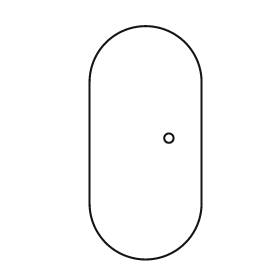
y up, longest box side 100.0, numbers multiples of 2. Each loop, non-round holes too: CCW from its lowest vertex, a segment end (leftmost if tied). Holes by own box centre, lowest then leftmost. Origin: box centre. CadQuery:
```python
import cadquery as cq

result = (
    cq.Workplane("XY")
    .moveTo(-24.0, -26.0)
    .threePointArc((0.0, -50.0), (24.0, -26.0))
    .lineTo(24.0, 26.0)
    .threePointArc((0.0, 50.0), (-24.0, 26.0))
    .close()
    .moveTo(10.0, 2.0)
    .circle(2.0)
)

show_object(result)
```